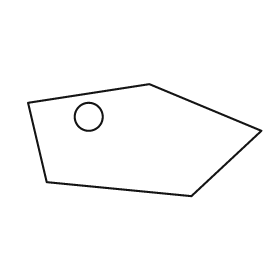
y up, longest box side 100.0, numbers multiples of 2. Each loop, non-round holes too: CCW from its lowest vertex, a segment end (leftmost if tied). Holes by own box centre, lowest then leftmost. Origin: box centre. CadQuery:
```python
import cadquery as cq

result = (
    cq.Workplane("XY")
    .moveTo(20.0, -24.0)
    .lineTo(50.0, 4.0)
    .lineTo(2.0, 24.0)
    .lineTo(-50.0, 16.0)
    .lineTo(-42.0, -18.0)
    .close()
    .moveTo(-24.0, 10.0)
    .circle(6.0)
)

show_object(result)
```